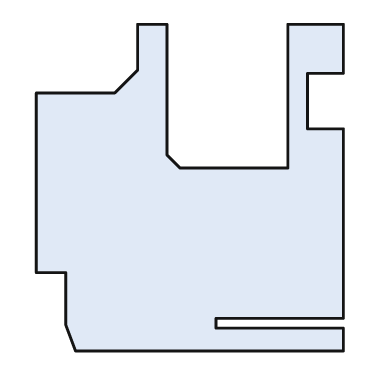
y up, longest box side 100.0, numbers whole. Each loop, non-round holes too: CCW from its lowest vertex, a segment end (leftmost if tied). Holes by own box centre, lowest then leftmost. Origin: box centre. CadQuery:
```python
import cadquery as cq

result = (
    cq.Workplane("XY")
    .moveTo(-35.0, -50.0)
    .lineTo(47.0, -50.0)
    .lineTo(47.0, -43.0)
    .lineTo(8.0, -43.0)
    .lineTo(8.0, -40.0)
    .lineTo(47.0, -40.0)
    .lineTo(47.0, 18.0)
    .lineTo(36.0, 18.0)
    .lineTo(36.0, 35.0)
    .lineTo(47.0, 35.0)
    .lineTo(47.0, 50.0)
    .lineTo(30.0, 50.0)
    .lineTo(30.0, 6.0)
    .lineTo(-3.0, 6.0)
    .lineTo(-7.0, 10.0)
    .lineTo(-7.0, 50.0)
    .lineTo(-16.0, 50.0)
    .lineTo(-16.0, 36.0)
    .lineTo(-23.0, 29.0)
    .lineTo(-47.0, 29.0)
    .lineTo(-47.0, -26.0)
    .lineTo(-38.0, -26.0)
    .lineTo(-38.0, -42.0)
    .close()
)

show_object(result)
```